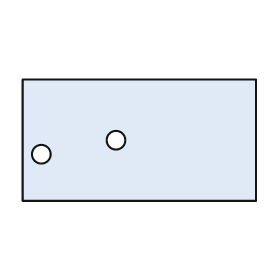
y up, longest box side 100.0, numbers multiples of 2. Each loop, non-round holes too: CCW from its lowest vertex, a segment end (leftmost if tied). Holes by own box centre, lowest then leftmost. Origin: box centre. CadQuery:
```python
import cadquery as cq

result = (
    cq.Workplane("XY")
    .moveTo(-50.0, -26.0)
    .lineTo(50.0, -26.0)
    .lineTo(50.0, 26.0)
    .lineTo(-50.0, 26.0)
    .close()
    .moveTo(-42.0, -6.0)
    .circle(4.0)
    .moveTo(-10.0, 0.0)
    .circle(4.0)
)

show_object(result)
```